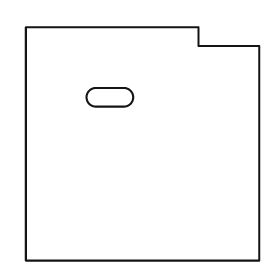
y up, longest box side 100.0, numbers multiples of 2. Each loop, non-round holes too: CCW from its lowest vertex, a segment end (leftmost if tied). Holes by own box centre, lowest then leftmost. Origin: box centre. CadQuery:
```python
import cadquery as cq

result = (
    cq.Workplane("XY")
    .moveTo(-50.0, -50.0)
    .lineTo(50.0, -50.0)
    .lineTo(50.0, 42.0)
    .lineTo(24.0, 42.0)
    .lineTo(24.0, 50.0)
    .lineTo(-50.0, 50.0)
    .close()
    .moveTo(-20.0, 16.0)
    .lineTo(-8.0, 16.0)
    .threePointArc((-4.0, 20.0), (-8.0, 24.0))
    .lineTo(-20.0, 24.0)
    .threePointArc((-24.0, 20.0), (-20.0, 16.0))
    .close()
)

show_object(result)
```